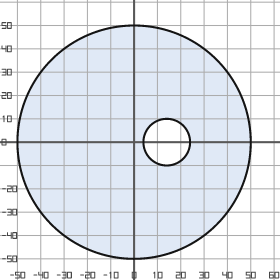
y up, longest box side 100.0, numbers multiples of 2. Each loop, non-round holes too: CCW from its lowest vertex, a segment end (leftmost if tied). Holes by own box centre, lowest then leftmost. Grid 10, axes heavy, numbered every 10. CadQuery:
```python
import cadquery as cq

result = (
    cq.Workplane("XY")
    .moveTo(0.0, 0.0)
    .circle(50.0)
    .moveTo(14.0, 0.0)
    .circle(10.0)
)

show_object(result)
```